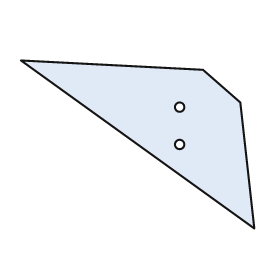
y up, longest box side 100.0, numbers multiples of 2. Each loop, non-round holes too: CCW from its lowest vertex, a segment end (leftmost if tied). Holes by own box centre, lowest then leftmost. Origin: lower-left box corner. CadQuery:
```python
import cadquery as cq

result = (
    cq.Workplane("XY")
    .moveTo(100.0, 0.0)
    .lineTo(94.0, 54.0)
    .lineTo(78.0, 68.0)
    .lineTo(0.0, 72.0)
    .close()
    .moveTo(68.0, 36.0)
    .circle(2.0)
    .moveTo(68.0, 52.0)
    .circle(2.0)
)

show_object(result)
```